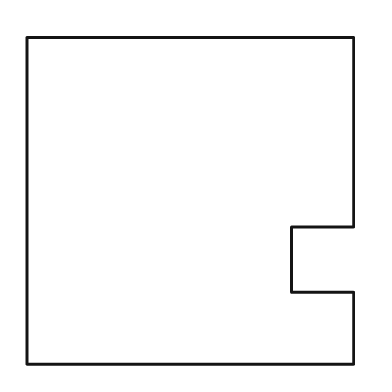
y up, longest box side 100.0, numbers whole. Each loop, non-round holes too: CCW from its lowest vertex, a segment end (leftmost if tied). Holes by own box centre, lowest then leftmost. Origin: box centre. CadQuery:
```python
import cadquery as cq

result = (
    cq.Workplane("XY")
    .moveTo(-50.0, -50.0)
    .lineTo(50.0, -50.0)
    .lineTo(50.0, -28.0)
    .lineTo(31.0, -28.0)
    .lineTo(31.0, -8.0)
    .lineTo(50.0, -8.0)
    .lineTo(50.0, 50.0)
    .lineTo(-50.0, 50.0)
    .close()
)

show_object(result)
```